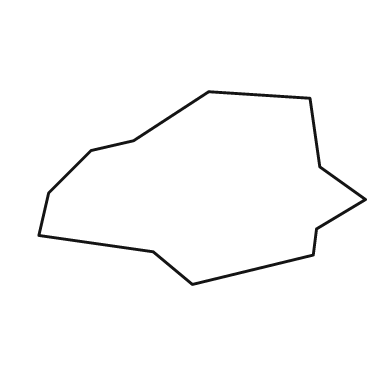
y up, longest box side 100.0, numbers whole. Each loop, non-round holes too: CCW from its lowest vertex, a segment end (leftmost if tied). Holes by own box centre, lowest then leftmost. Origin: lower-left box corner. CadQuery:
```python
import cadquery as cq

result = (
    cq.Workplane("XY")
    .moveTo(47.0, 0.0)
    .lineTo(84.0, 9.0)
    .lineTo(85.0, 17.0)
    .lineTo(100.0, 26.0)
    .lineTo(86.0, 36.0)
    .lineTo(83.0, 57.0)
    .lineTo(52.0, 59.0)
    .lineTo(29.0, 44.0)
    .lineTo(16.0, 41.0)
    .lineTo(3.0, 28.0)
    .lineTo(0.0, 15.0)
    .lineTo(35.0, 10.0)
    .close()
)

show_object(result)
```